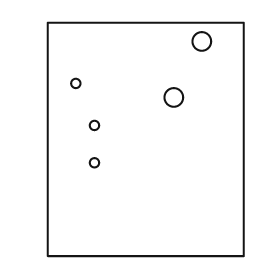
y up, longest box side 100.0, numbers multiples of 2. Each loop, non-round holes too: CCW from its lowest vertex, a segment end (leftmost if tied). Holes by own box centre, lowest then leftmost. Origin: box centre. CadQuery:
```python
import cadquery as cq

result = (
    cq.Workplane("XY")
    .moveTo(-42.0, -50.0)
    .lineTo(42.0, -50.0)
    .lineTo(42.0, 50.0)
    .lineTo(-42.0, 50.0)
    .close()
    .moveTo(-22.0, -10.0)
    .circle(2.0)
    .moveTo(-22.0, 6.0)
    .circle(2.0)
    .moveTo(12.0, 18.0)
    .circle(4.0)
    .moveTo(-30.0, 24.0)
    .circle(2.0)
    .moveTo(24.0, 42.0)
    .circle(4.0)
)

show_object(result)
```